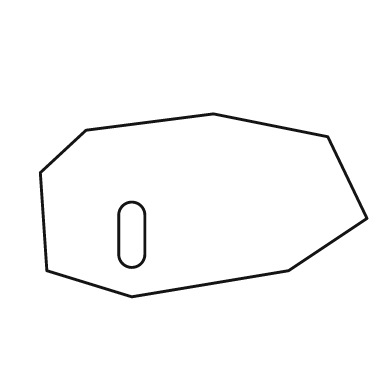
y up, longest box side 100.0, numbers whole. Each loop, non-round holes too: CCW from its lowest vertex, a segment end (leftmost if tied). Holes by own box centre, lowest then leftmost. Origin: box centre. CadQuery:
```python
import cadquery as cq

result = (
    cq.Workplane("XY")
    .moveTo(-22.0, -28.0)
    .lineTo(26.0, -20.0)
    .lineTo(50.0, -4.0)
    .lineTo(38.0, 21.0)
    .lineTo(3.0, 28.0)
    .lineTo(-36.0, 23.0)
    .lineTo(-50.0, 10.0)
    .lineTo(-48.0, -20.0)
    .close()
    .moveTo(-26.0, -15.0)
    .threePointArc((-22.0, -19.0), (-18.0, -15.0))
    .lineTo(-18.0, -3.0)
    .threePointArc((-22.0, 1.0), (-26.0, -3.0))
    .close()
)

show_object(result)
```